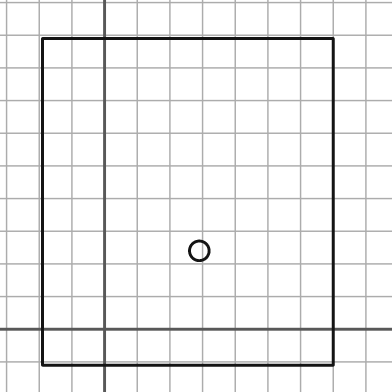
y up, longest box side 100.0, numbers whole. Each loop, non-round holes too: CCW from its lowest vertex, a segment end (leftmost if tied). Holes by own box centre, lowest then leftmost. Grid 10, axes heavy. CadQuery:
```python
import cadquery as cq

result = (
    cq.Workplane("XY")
    .moveTo(-19.0, -11.0)
    .lineTo(70.0, -11.0)
    .lineTo(70.0, 89.0)
    .lineTo(-19.0, 89.0)
    .close()
    .moveTo(29.0, 24.0)
    .circle(3.0)
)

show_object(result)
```